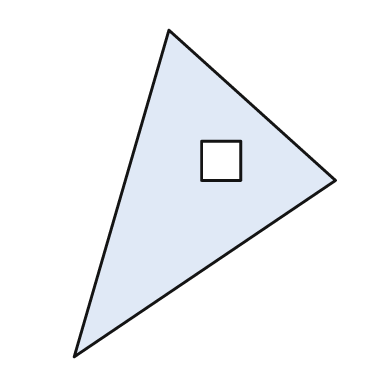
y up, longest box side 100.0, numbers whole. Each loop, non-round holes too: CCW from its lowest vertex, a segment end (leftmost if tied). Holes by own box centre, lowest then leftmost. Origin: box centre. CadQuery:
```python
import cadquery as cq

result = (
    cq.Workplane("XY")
    .moveTo(-40.0, -50.0)
    .lineTo(40.0, 4.0)
    .lineTo(-11.0, 50.0)
    .close()
    .moveTo(-1.0, 4.0)
    .lineTo(11.0, 4.0)
    .lineTo(11.0, 16.0)
    .lineTo(-1.0, 16.0)
    .close()
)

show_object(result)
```